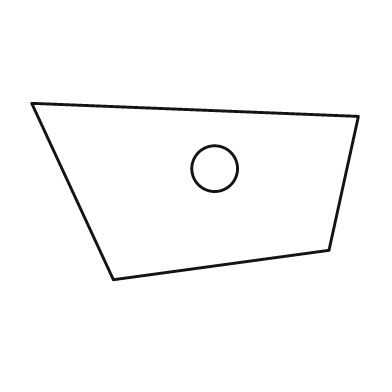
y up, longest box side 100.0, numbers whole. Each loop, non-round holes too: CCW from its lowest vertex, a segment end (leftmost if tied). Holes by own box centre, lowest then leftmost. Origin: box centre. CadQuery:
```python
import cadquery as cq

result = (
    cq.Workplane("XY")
    .moveTo(-25.0, -27.0)
    .lineTo(41.0, -18.0)
    .lineTo(50.0, 23.0)
    .lineTo(-50.0, 27.0)
    .close()
    .moveTo(6.0, 7.0)
    .circle(7.0)
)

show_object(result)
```